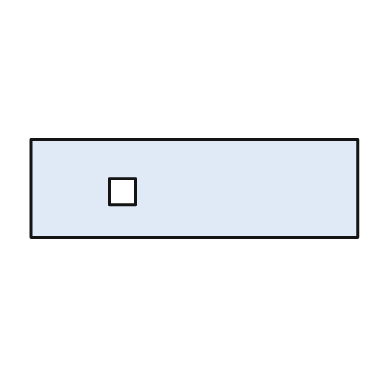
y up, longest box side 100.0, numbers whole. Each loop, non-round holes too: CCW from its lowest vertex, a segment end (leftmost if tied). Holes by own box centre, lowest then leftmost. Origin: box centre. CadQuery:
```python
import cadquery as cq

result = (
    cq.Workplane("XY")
    .moveTo(-50.0, -15.0)
    .lineTo(50.0, -15.0)
    .lineTo(50.0, 15.0)
    .lineTo(-50.0, 15.0)
    .close()
    .moveTo(-26.0, -5.0)
    .lineTo(-18.0, -5.0)
    .lineTo(-18.0, 3.0)
    .lineTo(-26.0, 3.0)
    .close()
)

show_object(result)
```